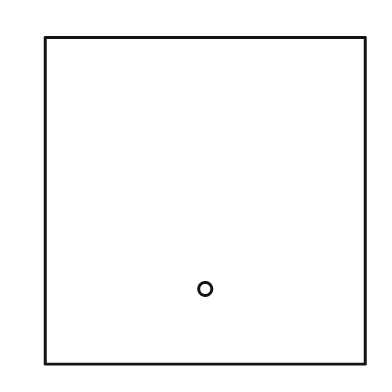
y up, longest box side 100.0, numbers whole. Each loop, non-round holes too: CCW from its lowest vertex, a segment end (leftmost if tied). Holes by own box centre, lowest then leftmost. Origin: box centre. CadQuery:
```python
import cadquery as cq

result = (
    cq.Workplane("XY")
    .moveTo(-49.0, -50.0)
    .lineTo(49.0, -50.0)
    .lineTo(49.0, 50.0)
    .lineTo(-49.0, 50.0)
    .close()
    .moveTo(0.0, -27.0)
    .circle(2.0)
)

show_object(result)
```